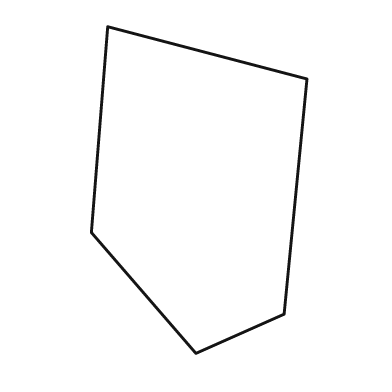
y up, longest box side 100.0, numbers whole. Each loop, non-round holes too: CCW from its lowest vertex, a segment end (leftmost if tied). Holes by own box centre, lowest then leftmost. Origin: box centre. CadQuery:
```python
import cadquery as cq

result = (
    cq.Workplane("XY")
    .moveTo(-1.0, -50.0)
    .lineTo(26.0, -38.0)
    .lineTo(33.0, 34.0)
    .lineTo(-28.0, 50.0)
    .lineTo(-33.0, -13.0)
    .close()
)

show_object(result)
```